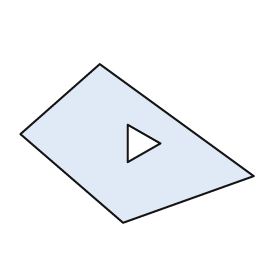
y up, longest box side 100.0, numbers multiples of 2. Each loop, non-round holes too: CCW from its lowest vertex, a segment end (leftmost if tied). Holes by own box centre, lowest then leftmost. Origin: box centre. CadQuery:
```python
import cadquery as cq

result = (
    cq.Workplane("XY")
    .moveTo(-6.0, -34.0)
    .lineTo(50.0, -14.0)
    .lineTo(-16.0, 34.0)
    .lineTo(-50.0, 4.0)
    .close()
    .moveTo(-4.0, -8.0)
    .lineTo(10.0, 0.0)
    .lineTo(-4.0, 8.0)
    .close()
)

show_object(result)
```